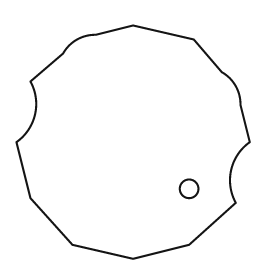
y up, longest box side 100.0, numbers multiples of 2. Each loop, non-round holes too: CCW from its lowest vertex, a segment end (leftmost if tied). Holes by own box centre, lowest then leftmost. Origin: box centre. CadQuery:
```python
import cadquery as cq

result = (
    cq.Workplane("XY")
    .moveTo(0.0, -50.0)
    .lineTo(24.0, -44.0)
    .lineTo(44.0, -26.0)
    .threePointArc((42.0, -12.0), (50.0, 0.0))
    .lineTo(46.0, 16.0)
    .threePointArc((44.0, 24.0), (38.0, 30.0))
    .lineTo(26.0, 44.0)
    .lineTo(0.0, 50.0)
    .lineTo(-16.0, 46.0)
    .threePointArc((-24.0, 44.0), (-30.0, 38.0))
    .lineTo(-44.0, 26.0)
    .threePointArc((-42.0, 12.0), (-50.0, 0.0))
    .lineTo(-44.0, -24.0)
    .lineTo(-26.0, -44.0)
    .close()
    .moveTo(24.0, -20.0)
    .circle(4.0)
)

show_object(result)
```